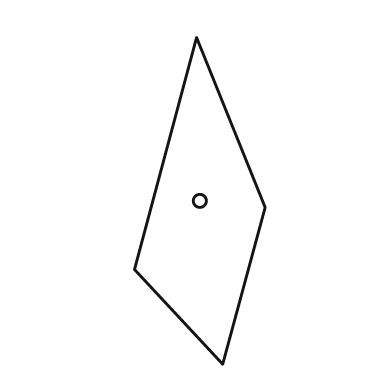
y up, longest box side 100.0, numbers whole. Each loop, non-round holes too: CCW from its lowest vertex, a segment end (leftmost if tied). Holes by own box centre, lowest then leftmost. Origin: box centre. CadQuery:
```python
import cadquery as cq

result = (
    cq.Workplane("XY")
    .moveTo(7.0, -50.0)
    .lineTo(20.0, -2.0)
    .lineTo(-1.0, 50.0)
    .lineTo(-20.0, -21.0)
    .close()
    .moveTo(0.0, 0.0)
    .circle(2.0)
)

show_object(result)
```